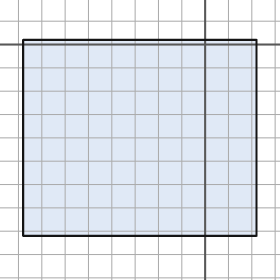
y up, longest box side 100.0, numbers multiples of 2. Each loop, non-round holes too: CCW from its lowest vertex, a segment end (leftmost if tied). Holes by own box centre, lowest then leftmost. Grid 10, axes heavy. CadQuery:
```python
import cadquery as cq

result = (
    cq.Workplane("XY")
    .moveTo(-78.0, -82.0)
    .lineTo(22.0, -82.0)
    .lineTo(22.0, 2.0)
    .lineTo(-78.0, 2.0)
    .close()
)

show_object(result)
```